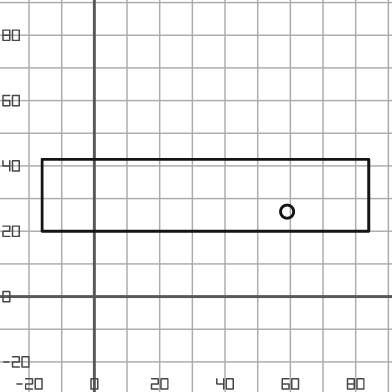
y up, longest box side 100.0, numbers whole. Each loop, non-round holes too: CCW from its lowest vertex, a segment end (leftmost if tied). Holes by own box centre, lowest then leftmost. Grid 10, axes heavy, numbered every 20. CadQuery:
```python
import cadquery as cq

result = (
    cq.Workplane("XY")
    .moveTo(-16.0, 20.0)
    .lineTo(84.0, 20.0)
    .lineTo(84.0, 42.0)
    .lineTo(-16.0, 42.0)
    .close()
    .moveTo(59.0, 26.0)
    .circle(2.0)
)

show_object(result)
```